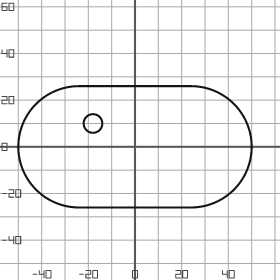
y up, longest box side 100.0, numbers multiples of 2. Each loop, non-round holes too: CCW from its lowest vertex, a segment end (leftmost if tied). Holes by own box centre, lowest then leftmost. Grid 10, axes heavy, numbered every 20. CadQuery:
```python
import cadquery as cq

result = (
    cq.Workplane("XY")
    .moveTo(-24.0, -26.0)
    .lineTo(24.0, -26.0)
    .threePointArc((50.0, 0.0), (24.0, 26.0))
    .lineTo(-24.0, 26.0)
    .threePointArc((-50.0, 0.0), (-24.0, -26.0))
    .close()
    .moveTo(-18.0, 10.0)
    .circle(4.0)
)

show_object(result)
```